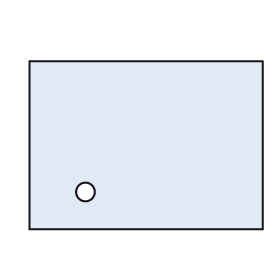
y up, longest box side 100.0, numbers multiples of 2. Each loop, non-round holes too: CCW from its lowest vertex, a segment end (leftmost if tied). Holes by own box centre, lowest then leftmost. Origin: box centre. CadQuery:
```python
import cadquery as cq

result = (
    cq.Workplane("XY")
    .moveTo(-50.0, -36.0)
    .lineTo(50.0, -36.0)
    .lineTo(50.0, 36.0)
    .lineTo(-50.0, 36.0)
    .close()
    .moveTo(-26.0, -20.0)
    .circle(4.0)
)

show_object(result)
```